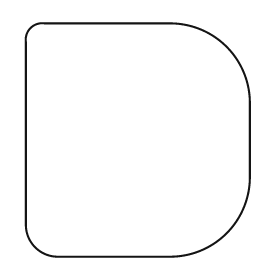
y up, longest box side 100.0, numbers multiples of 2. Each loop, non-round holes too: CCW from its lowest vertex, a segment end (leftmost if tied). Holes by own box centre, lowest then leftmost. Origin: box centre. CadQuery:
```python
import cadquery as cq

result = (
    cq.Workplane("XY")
    .moveTo(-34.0, -50.0)
    .lineTo(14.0, -50.0)
    .threePointArc((38.0, -40.0), (48.0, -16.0))
    .lineTo(48.0, 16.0)
    .threePointArc((38.0, 40.0), (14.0, 50.0))
    .lineTo(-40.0, 50.0)
    .threePointArc((-46.0, 48.0), (-48.0, 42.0))
    .lineTo(-48.0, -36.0)
    .threePointArc((-44.0, -46.0), (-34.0, -50.0))
    .close()
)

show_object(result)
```